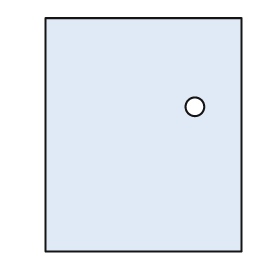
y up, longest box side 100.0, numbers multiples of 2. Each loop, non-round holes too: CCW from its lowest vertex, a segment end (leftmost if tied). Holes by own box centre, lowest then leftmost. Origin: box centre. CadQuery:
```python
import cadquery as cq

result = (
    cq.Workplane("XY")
    .moveTo(-42.0, -50.0)
    .lineTo(42.0, -50.0)
    .lineTo(42.0, 50.0)
    .lineTo(-42.0, 50.0)
    .close()
    .moveTo(22.0, 12.0)
    .circle(4.0)
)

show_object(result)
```